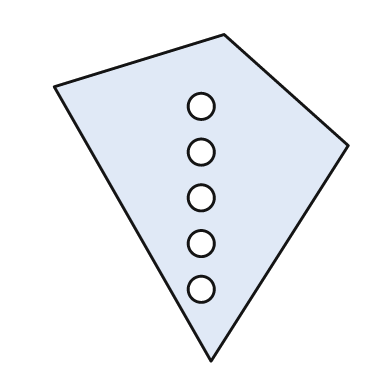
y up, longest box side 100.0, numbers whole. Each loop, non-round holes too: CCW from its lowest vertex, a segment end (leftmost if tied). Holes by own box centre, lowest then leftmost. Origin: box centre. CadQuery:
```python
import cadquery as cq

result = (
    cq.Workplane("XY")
    .moveTo(3.0, -50.0)
    .lineTo(45.0, 16.0)
    .lineTo(7.0, 50.0)
    .lineTo(-45.0, 34.0)
    .close()
    .moveTo(0.0, -28.0)
    .circle(4.0)
    .moveTo(0.0, -14.0)
    .circle(4.0)
    .moveTo(0.0, 0.0)
    .circle(4.0)
    .moveTo(0.0, 14.0)
    .circle(4.0)
    .moveTo(0.0, 28.0)
    .circle(4.0)
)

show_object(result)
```